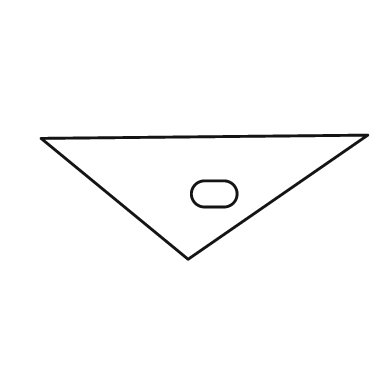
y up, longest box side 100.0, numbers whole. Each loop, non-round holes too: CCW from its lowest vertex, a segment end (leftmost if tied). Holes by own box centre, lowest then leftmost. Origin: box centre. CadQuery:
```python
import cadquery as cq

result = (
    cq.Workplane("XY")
    .moveTo(-5.0, -19.0)
    .lineTo(50.0, 19.0)
    .lineTo(-50.0, 18.0)
    .close()
    .moveTo(0.0, -3.0)
    .lineTo(6.0, -3.0)
    .threePointArc((10.0, 1.0), (6.0, 5.0))
    .lineTo(0.0, 5.0)
    .threePointArc((-4.0, 1.0), (0.0, -3.0))
    .close()
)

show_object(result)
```